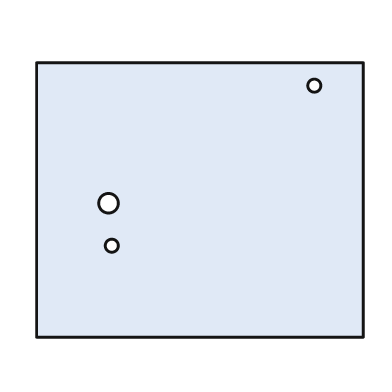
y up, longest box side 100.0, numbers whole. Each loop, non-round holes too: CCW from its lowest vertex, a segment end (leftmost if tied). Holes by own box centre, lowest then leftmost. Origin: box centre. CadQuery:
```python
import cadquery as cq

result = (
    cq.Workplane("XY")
    .moveTo(-50.0, -42.0)
    .lineTo(50.0, -42.0)
    .lineTo(50.0, 42.0)
    .lineTo(-50.0, 42.0)
    .close()
    .moveTo(-27.0, -14.0)
    .circle(2.0)
    .moveTo(-28.0, -1.0)
    .circle(3.0)
    .moveTo(35.0, 35.0)
    .circle(2.0)
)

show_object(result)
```